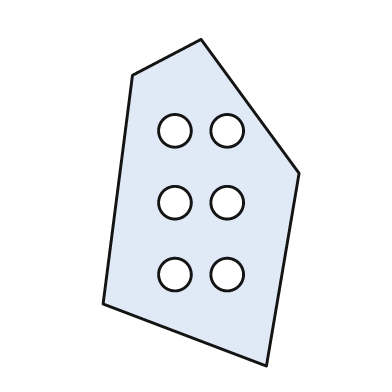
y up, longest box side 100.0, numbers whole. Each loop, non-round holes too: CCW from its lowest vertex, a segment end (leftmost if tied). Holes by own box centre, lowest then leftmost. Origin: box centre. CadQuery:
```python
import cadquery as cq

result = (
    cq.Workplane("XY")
    .moveTo(20.0, -50.0)
    .lineTo(30.0, 9.0)
    .lineTo(0.0, 50.0)
    .lineTo(-21.0, 39.0)
    .lineTo(-30.0, -31.0)
    .close()
    .moveTo(-8.0, -22.0)
    .circle(5.0)
    .moveTo(8.0, -22.0)
    .circle(5.0)
    .moveTo(-8.0, 0.0)
    .circle(5.0)
    .moveTo(8.0, 0.0)
    .circle(5.0)
    .moveTo(-8.0, 22.0)
    .circle(5.0)
    .moveTo(8.0, 22.0)
    .circle(5.0)
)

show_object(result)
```